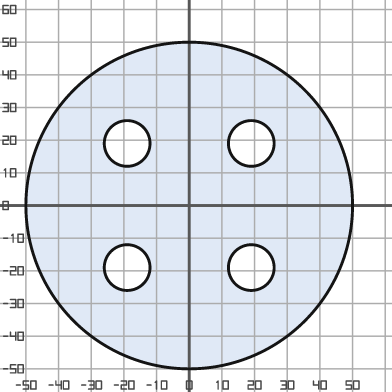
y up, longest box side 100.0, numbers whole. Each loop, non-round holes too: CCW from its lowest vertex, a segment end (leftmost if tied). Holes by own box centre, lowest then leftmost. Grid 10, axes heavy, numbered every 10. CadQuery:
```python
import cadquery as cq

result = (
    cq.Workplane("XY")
    .moveTo(0.0, 0.0)
    .circle(50.0)
    .moveTo(-19.0, -19.0)
    .circle(7.0)
    .moveTo(19.0, -19.0)
    .circle(7.0)
    .moveTo(-19.0, 19.0)
    .circle(7.0)
    .moveTo(19.0, 19.0)
    .circle(7.0)
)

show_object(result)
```